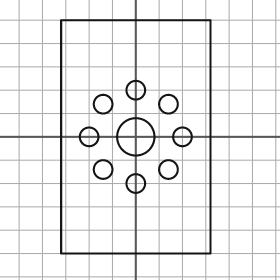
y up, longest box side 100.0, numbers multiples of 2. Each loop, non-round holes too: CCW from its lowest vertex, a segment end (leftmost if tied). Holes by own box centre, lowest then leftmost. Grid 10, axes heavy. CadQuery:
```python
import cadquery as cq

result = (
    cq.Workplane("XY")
    .moveTo(-32.0, -50.0)
    .lineTo(32.0, -50.0)
    .lineTo(32.0, 50.0)
    .lineTo(-32.0, 50.0)
    .close()
    .moveTo(0.0, -20.0)
    .circle(4.0)
    .moveTo(-14.0, -14.0)
    .circle(4.0)
    .moveTo(14.0, -14.0)
    .circle(4.0)
    .moveTo(-20.0, 0.0)
    .circle(4.0)
    .moveTo(0.0, 0.0)
    .circle(8.0)
    .moveTo(20.0, 0.0)
    .circle(4.0)
    .moveTo(-14.0, 14.0)
    .circle(4.0)
    .moveTo(14.0, 14.0)
    .circle(4.0)
    .moveTo(0.0, 20.0)
    .circle(4.0)
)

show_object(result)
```